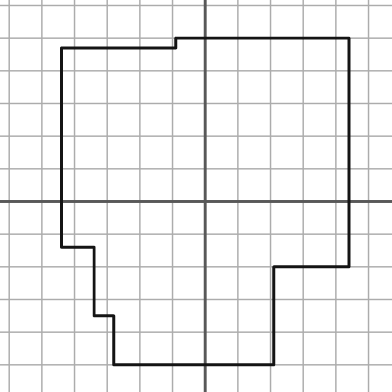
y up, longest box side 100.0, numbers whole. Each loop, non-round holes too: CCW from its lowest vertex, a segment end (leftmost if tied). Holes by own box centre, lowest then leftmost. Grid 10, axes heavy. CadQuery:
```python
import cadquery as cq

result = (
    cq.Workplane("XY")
    .moveTo(-28.0, -50.0)
    .lineTo(21.0, -50.0)
    .lineTo(21.0, -20.0)
    .lineTo(44.0, -20.0)
    .lineTo(44.0, 50.0)
    .lineTo(-9.0, 50.0)
    .lineTo(-9.0, 47.0)
    .lineTo(-44.0, 47.0)
    .lineTo(-44.0, -14.0)
    .lineTo(-34.0, -14.0)
    .lineTo(-34.0, -35.0)
    .lineTo(-28.0, -35.0)
    .close()
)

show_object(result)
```